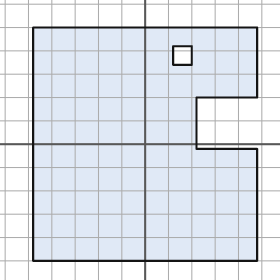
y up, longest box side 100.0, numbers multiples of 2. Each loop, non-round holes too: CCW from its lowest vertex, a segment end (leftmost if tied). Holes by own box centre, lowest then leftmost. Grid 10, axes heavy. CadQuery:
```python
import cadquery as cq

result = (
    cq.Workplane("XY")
    .moveTo(-48.0, -50.0)
    .lineTo(48.0, -50.0)
    .lineTo(48.0, -2.0)
    .lineTo(22.0, -2.0)
    .lineTo(22.0, 20.0)
    .lineTo(48.0, 20.0)
    .lineTo(48.0, 50.0)
    .lineTo(-48.0, 50.0)
    .close()
    .moveTo(12.0, 34.0)
    .lineTo(20.0, 34.0)
    .lineTo(20.0, 42.0)
    .lineTo(12.0, 42.0)
    .close()
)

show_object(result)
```